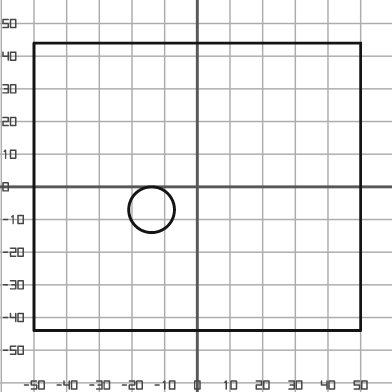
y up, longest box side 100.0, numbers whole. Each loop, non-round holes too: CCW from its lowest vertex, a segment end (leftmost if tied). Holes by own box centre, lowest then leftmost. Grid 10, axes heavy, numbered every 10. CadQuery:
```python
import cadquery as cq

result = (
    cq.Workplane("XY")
    .moveTo(-50.0, -44.0)
    .lineTo(50.0, -44.0)
    .lineTo(50.0, 44.0)
    .lineTo(-50.0, 44.0)
    .close()
    .moveTo(-14.0, -7.0)
    .circle(7.0)
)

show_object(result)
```